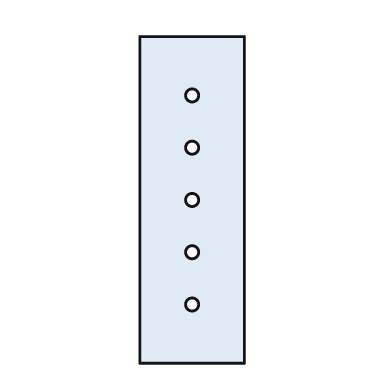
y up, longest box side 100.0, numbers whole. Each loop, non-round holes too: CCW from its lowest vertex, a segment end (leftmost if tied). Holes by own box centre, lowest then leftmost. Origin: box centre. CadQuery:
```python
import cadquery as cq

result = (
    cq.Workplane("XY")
    .moveTo(-16.0, -50.0)
    .lineTo(16.0, -50.0)
    .lineTo(16.0, 50.0)
    .lineTo(-16.0, 50.0)
    .close()
    .moveTo(0.0, -32.0)
    .circle(2.0)
    .moveTo(0.0, -16.0)
    .circle(2.0)
    .moveTo(0.0, 0.0)
    .circle(2.0)
    .moveTo(0.0, 16.0)
    .circle(2.0)
    .moveTo(0.0, 32.0)
    .circle(2.0)
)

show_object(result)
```